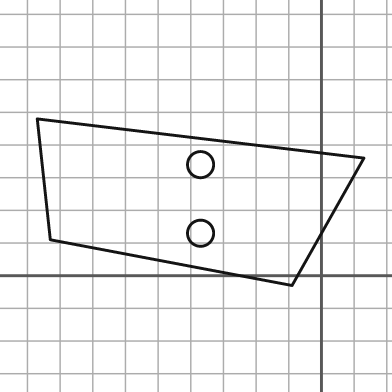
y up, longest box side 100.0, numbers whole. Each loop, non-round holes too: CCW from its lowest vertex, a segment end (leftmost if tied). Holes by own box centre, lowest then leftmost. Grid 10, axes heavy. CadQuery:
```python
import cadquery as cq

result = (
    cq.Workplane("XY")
    .moveTo(-9.0, -3.0)
    .lineTo(13.0, 36.0)
    .lineTo(-87.0, 48.0)
    .lineTo(-83.0, 11.0)
    .close()
    .moveTo(-37.0, 13.0)
    .circle(4.0)
    .moveTo(-37.0, 34.0)
    .circle(4.0)
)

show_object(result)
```